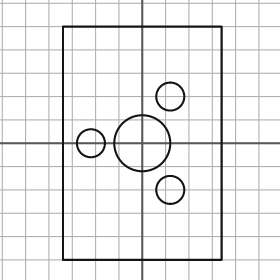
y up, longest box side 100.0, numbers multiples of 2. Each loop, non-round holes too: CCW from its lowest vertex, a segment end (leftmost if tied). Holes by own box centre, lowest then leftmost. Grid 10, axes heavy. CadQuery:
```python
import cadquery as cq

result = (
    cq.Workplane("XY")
    .moveTo(-34.0, -50.0)
    .lineTo(34.0, -50.0)
    .lineTo(34.0, 50.0)
    .lineTo(-34.0, 50.0)
    .close()
    .moveTo(12.0, -20.0)
    .circle(6.0)
    .moveTo(-22.0, 0.0)
    .circle(6.0)
    .moveTo(0.0, 0.0)
    .circle(12.0)
    .moveTo(12.0, 20.0)
    .circle(6.0)
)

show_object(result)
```